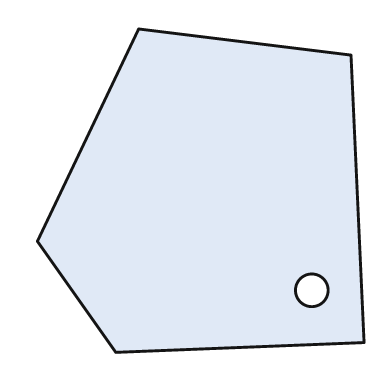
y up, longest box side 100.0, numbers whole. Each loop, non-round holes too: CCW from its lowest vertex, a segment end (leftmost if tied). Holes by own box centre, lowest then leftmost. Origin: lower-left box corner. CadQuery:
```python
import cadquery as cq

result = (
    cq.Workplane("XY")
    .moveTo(24.0, 0.0)
    .lineTo(100.0, 3.0)
    .lineTo(96.0, 91.0)
    .lineTo(31.0, 99.0)
    .lineTo(0.0, 34.0)
    .close()
    .moveTo(84.0, 19.0)
    .circle(5.0)
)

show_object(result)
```